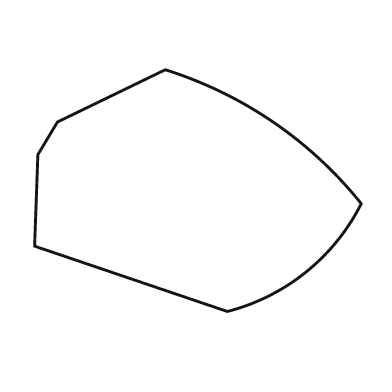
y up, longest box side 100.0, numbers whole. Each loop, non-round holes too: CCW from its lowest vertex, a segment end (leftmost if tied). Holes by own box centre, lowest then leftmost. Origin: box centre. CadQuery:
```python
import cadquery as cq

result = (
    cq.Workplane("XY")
    .moveTo(9.0, -37.0)
    .threePointArc((33.0, -25.0), (50.0, -4.0))
    .threePointArc((23.0, 21.0), (-10.0, 37.0))
    .lineTo(-43.0, 21.0)
    .lineTo(-49.0, 11.0)
    .lineTo(-50.0, -17.0)
    .close()
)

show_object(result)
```